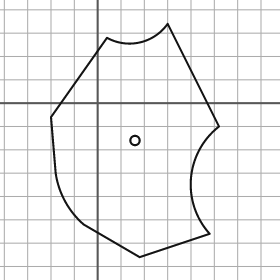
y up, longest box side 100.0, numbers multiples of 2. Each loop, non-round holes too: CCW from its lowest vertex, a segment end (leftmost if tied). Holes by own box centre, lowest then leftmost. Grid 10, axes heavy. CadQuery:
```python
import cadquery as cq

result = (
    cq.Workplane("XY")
    .moveTo(18.0, -66.0)
    .lineTo(48.0, -56.0)
    .threePointArc((40.0, -32.0), (52.0, -10.0))
    .lineTo(30.0, 34.0)
    .threePointArc((18.0, 26.0), (4.0, 28.0))
    .lineTo(-20.0, -6.0)
    .lineTo(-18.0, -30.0)
    .threePointArc((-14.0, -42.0), (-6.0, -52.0))
    .close()
    .moveTo(16.0, -16.0)
    .circle(2.0)
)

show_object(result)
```